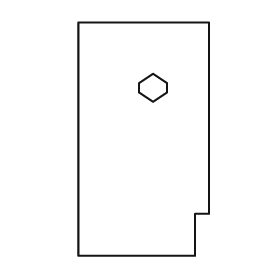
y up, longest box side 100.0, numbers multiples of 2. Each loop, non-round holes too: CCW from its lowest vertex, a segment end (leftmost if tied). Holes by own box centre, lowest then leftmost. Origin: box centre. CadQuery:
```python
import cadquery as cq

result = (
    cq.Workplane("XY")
    .moveTo(-28.0, -50.0)
    .lineTo(22.0, -50.0)
    .lineTo(22.0, -32.0)
    .lineTo(28.0, -32.0)
    .lineTo(28.0, 50.0)
    .lineTo(-28.0, 50.0)
    .close()
    .moveTo(4.0, 16.0)
    .lineTo(10.0, 20.0)
    .lineTo(10.0, 24.0)
    .lineTo(4.0, 28.0)
    .lineTo(-2.0, 24.0)
    .lineTo(-2.0, 20.0)
    .close()
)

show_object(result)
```